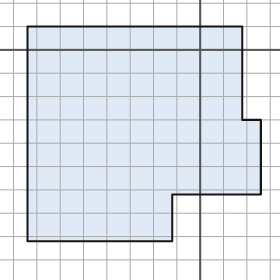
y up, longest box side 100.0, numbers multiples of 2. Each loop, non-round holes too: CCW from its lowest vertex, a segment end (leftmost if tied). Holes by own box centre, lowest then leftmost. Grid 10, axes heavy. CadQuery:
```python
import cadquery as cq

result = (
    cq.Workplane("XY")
    .moveTo(-74.0, -82.0)
    .lineTo(-12.0, -82.0)
    .lineTo(-12.0, -62.0)
    .lineTo(26.0, -62.0)
    .lineTo(26.0, -30.0)
    .lineTo(18.0, -30.0)
    .lineTo(18.0, 10.0)
    .lineTo(-74.0, 10.0)
    .close()
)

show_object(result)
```